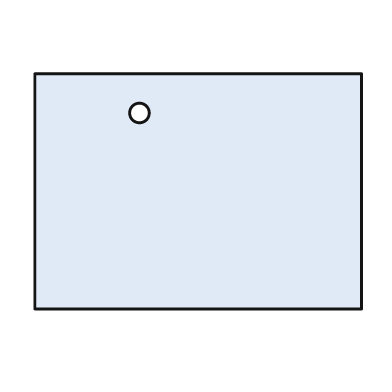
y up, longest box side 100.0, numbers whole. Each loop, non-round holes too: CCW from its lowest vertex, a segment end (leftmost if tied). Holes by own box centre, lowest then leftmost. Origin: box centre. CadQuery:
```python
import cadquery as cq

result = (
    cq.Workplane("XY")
    .moveTo(-50.0, -36.0)
    .lineTo(50.0, -36.0)
    .lineTo(50.0, 36.0)
    .lineTo(-50.0, 36.0)
    .close()
    .moveTo(-18.0, 24.0)
    .circle(3.0)
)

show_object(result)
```